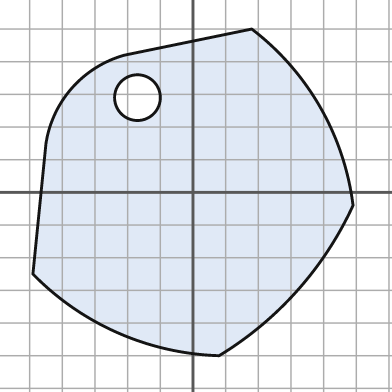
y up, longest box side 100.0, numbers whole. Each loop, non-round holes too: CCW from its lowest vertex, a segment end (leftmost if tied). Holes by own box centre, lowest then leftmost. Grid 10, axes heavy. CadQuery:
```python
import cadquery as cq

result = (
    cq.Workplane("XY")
    .moveTo(8.0, -50.0)
    .threePointArc((32.0, -30.0), (49.0, -4.0))
    .threePointArc((39.0, 26.0), (18.0, 50.0))
    .lineTo(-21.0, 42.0)
    .threePointArc((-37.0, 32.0), (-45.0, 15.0))
    .lineTo(-49.0, -25.0)
    .threePointArc((-23.0, -43.0), (8.0, -50.0))
    .close()
    .moveTo(-17.0, 29.0)
    .circle(7.0)
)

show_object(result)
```